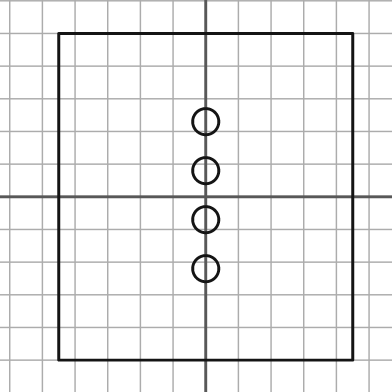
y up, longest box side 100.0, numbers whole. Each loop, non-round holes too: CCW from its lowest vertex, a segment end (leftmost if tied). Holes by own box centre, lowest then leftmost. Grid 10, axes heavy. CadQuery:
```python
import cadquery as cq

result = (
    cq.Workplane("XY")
    .moveTo(-45.0, -50.0)
    .lineTo(45.0, -50.0)
    .lineTo(45.0, 50.0)
    .lineTo(-45.0, 50.0)
    .close()
    .moveTo(0.0, -22.0)
    .circle(4.0)
    .moveTo(0.0, -7.0)
    .circle(4.0)
    .moveTo(0.0, 8.0)
    .circle(4.0)
    .moveTo(0.0, 23.0)
    .circle(4.0)
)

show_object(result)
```